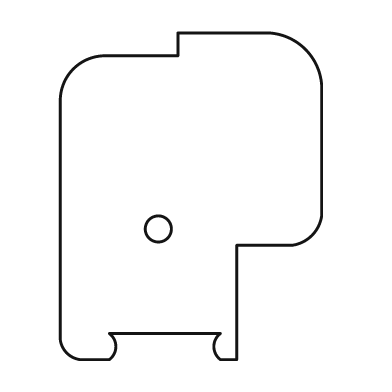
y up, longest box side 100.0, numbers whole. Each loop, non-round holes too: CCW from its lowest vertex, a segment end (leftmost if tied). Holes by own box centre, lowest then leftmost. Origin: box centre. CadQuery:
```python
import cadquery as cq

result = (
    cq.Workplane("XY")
    .moveTo(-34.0, -50.0)
    .lineTo(-25.0, -50.0)
    .threePointArc((-23.0, -46.0), (-25.0, -42.0))
    .lineTo(9.0, -42.0)
    .threePointArc((7.0, -46.0), (9.0, -50.0))
    .lineTo(14.0, -50.0)
    .lineTo(14.0, -15.0)
    .lineTo(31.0, -15.0)
    .threePointArc((37.0, -12.0), (40.0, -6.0))
    .lineTo(40.0, 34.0)
    .threePointArc((35.0, 45.0), (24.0, 50.0))
    .lineTo(-4.0, 50.0)
    .lineTo(-4.0, 43.0)
    .lineTo(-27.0, 43.0)
    .threePointArc((-36.0, 39.0), (-40.0, 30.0))
    .lineTo(-40.0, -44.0)
    .threePointArc((-38.0, -48.0), (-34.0, -50.0))
    .close()
    .moveTo(-10.0, -10.0)
    .circle(4.0)
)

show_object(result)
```